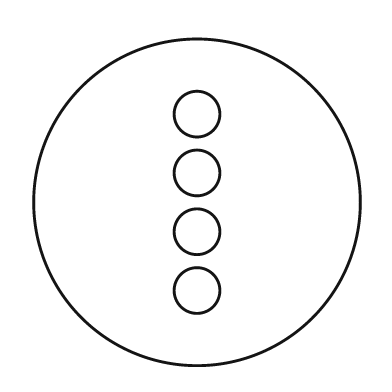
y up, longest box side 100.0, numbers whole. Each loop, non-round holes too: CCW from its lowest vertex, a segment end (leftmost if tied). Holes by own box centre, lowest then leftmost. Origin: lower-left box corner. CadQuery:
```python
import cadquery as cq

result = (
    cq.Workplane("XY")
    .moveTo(50.0, 50.0)
    .circle(50.0)
    .moveTo(50.0, 23.0)
    .circle(7.0)
    .moveTo(50.0, 41.0)
    .circle(7.0)
    .moveTo(50.0, 59.0)
    .circle(7.0)
    .moveTo(50.0, 77.0)
    .circle(7.0)
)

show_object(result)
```